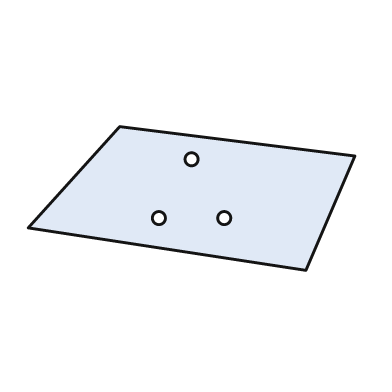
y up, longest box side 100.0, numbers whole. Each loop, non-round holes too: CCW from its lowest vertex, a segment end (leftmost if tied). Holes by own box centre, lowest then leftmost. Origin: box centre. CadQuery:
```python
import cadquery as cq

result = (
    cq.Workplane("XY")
    .moveTo(35.0, -22.0)
    .lineTo(50.0, 13.0)
    .lineTo(-22.0, 22.0)
    .lineTo(-50.0, -9.0)
    .close()
    .moveTo(-10.0, -6.0)
    .circle(2.0)
    .moveTo(10.0, -6.0)
    .circle(2.0)
    .moveTo(0.0, 12.0)
    .circle(2.0)
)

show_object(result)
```